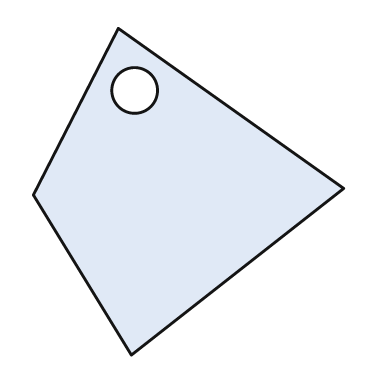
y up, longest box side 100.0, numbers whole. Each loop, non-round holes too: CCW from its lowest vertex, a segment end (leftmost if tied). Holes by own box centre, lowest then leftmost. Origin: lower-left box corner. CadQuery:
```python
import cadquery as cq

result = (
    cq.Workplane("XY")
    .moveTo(30.0, 0.0)
    .lineTo(95.0, 51.0)
    .lineTo(26.0, 100.0)
    .lineTo(0.0, 49.0)
    .close()
    .moveTo(31.0, 81.0)
    .circle(7.0)
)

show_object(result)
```